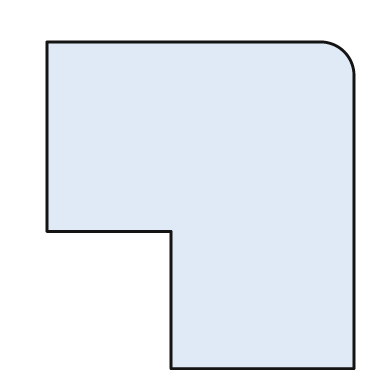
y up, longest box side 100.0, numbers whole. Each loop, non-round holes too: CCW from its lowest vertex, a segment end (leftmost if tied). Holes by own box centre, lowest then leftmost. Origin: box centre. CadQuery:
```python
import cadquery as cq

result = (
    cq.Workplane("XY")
    .moveTo(-9.0, -50.0)
    .lineTo(47.0, -50.0)
    .lineTo(47.0, 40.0)
    .threePointArc((44.0, 47.0), (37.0, 50.0))
    .lineTo(-47.0, 50.0)
    .lineTo(-47.0, -8.0)
    .lineTo(-9.0, -8.0)
    .close()
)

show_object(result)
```